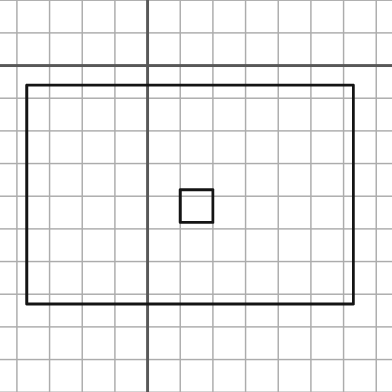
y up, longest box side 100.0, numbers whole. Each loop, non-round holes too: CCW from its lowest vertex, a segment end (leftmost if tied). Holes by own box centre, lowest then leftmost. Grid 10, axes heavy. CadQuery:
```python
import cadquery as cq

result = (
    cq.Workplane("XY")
    .moveTo(-37.0, -73.0)
    .lineTo(63.0, -73.0)
    .lineTo(63.0, -6.0)
    .lineTo(-37.0, -6.0)
    .close()
    .moveTo(10.0, -48.0)
    .lineTo(20.0, -48.0)
    .lineTo(20.0, -38.0)
    .lineTo(10.0, -38.0)
    .close()
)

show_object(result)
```